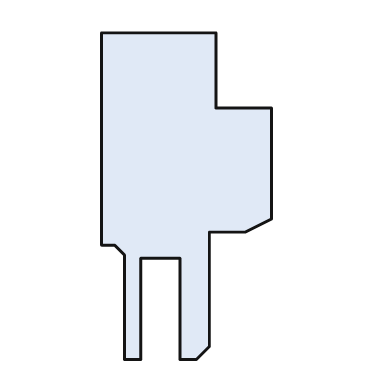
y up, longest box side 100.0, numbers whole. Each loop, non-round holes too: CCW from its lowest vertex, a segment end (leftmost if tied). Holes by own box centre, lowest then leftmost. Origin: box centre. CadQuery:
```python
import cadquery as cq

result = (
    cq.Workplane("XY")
    .moveTo(-19.0, -50.0)
    .lineTo(-14.0, -50.0)
    .lineTo(-14.0, -19.0)
    .lineTo(-2.0, -19.0)
    .lineTo(-2.0, -50.0)
    .lineTo(3.0, -50.0)
    .lineTo(7.0, -46.0)
    .lineTo(7.0, -11.0)
    .lineTo(18.0, -11.0)
    .lineTo(26.0, -7.0)
    .lineTo(26.0, 27.0)
    .lineTo(9.0, 27.0)
    .lineTo(9.0, 50.0)
    .lineTo(-26.0, 50.0)
    .lineTo(-26.0, -15.0)
    .lineTo(-22.0, -15.0)
    .lineTo(-19.0, -18.0)
    .close()
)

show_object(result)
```